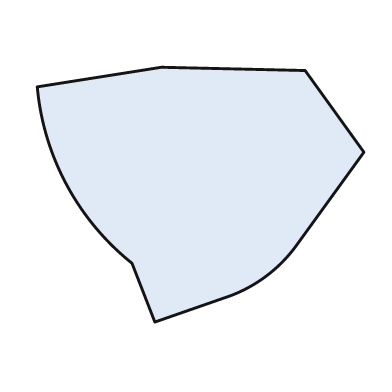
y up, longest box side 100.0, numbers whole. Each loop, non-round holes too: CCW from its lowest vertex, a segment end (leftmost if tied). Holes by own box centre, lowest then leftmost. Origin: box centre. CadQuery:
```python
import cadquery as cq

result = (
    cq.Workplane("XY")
    .moveTo(-14.0, -39.0)
    .lineTo(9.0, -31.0)
    .threePointArc((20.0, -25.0), (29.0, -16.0))
    .lineTo(50.0, 13.0)
    .lineTo(32.0, 38.0)
    .lineTo(-12.0, 39.0)
    .lineTo(-50.0, 33.0)
    .threePointArc((-41.0, 3.0), (-21.0, -21.0))
    .close()
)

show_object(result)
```